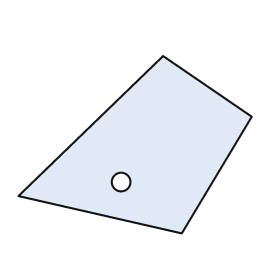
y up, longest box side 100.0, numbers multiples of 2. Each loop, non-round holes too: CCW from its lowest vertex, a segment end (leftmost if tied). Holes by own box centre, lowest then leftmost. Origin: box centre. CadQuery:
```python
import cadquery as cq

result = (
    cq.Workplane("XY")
    .moveTo(20.0, -38.0)
    .lineTo(50.0, 12.0)
    .lineTo(12.0, 38.0)
    .lineTo(-50.0, -22.0)
    .close()
    .moveTo(-6.0, -16.0)
    .circle(4.0)
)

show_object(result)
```